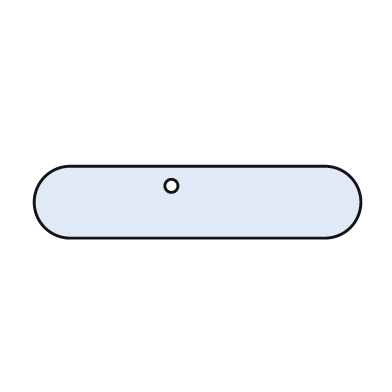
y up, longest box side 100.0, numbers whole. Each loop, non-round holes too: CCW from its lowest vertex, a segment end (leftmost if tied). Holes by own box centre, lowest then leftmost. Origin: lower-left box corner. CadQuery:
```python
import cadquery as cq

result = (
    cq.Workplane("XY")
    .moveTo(11.0, 0.0)
    .lineTo(89.0, 0.0)
    .threePointArc((100.0, 11.0), (89.0, 22.0))
    .lineTo(11.0, 22.0)
    .threePointArc((0.0, 11.0), (11.0, 0.0))
    .close()
    .moveTo(42.0, 16.0)
    .circle(2.0)
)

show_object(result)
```